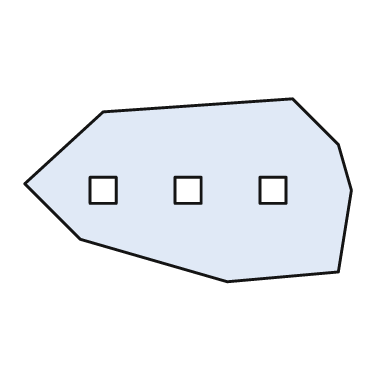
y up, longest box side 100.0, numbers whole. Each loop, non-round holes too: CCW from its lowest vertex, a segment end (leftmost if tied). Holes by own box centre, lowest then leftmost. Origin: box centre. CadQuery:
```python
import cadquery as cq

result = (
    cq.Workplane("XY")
    .moveTo(12.0, -28.0)
    .lineTo(46.0, -25.0)
    .lineTo(50.0, 0.0)
    .lineTo(46.0, 14.0)
    .lineTo(32.0, 28.0)
    .lineTo(-26.0, 24.0)
    .lineTo(-50.0, 2.0)
    .lineTo(-33.0, -15.0)
    .close()
    .moveTo(-30.0, -4.0)
    .lineTo(-22.0, -4.0)
    .lineTo(-22.0, 4.0)
    .lineTo(-30.0, 4.0)
    .close()
    .moveTo(-4.0, -4.0)
    .lineTo(4.0, -4.0)
    .lineTo(4.0, 4.0)
    .lineTo(-4.0, 4.0)
    .close()
    .moveTo(22.0, -4.0)
    .lineTo(30.0, -4.0)
    .lineTo(30.0, 4.0)
    .lineTo(22.0, 4.0)
    .close()
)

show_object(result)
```